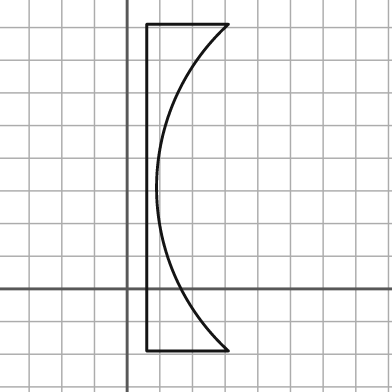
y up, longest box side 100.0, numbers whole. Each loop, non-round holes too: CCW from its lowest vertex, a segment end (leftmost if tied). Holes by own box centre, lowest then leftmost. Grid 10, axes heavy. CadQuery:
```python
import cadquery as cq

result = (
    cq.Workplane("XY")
    .moveTo(6.0, -19.0)
    .lineTo(31.0, -19.0)
    .threePointArc((9.0, 31.0), (31.0, 81.0))
    .lineTo(6.0, 81.0)
    .close()
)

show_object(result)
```